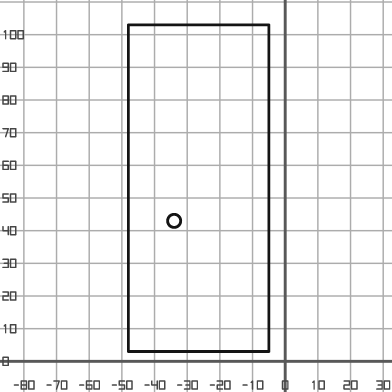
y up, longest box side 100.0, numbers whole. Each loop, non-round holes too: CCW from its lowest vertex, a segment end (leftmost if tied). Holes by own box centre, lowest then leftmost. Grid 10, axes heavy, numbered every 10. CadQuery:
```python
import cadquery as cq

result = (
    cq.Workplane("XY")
    .moveTo(-48.0, 3.0)
    .lineTo(-5.0, 3.0)
    .lineTo(-5.0, 103.0)
    .lineTo(-48.0, 103.0)
    .close()
    .moveTo(-34.0, 43.0)
    .circle(2.0)
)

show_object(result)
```